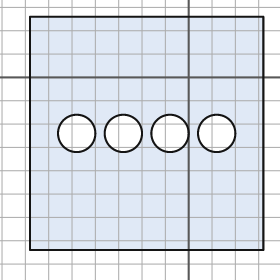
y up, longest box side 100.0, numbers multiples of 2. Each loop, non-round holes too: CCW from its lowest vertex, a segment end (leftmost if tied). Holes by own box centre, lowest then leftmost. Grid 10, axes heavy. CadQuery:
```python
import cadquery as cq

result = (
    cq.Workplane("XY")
    .moveTo(-68.0, -74.0)
    .lineTo(32.0, -74.0)
    .lineTo(32.0, 26.0)
    .lineTo(-68.0, 26.0)
    .close()
    .moveTo(-48.0, -24.0)
    .circle(8.0)
    .moveTo(-28.0, -24.0)
    .circle(8.0)
    .moveTo(-8.0, -24.0)
    .circle(8.0)
    .moveTo(12.0, -24.0)
    .circle(8.0)
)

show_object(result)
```